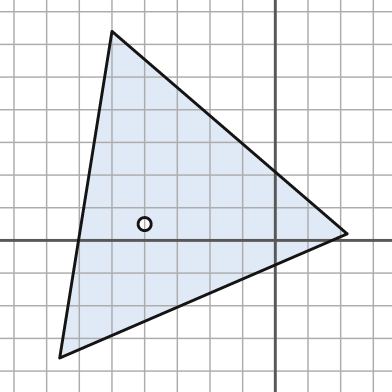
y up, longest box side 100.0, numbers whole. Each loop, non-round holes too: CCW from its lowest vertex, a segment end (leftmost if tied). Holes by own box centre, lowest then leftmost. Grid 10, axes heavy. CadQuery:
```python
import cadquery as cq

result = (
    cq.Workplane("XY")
    .moveTo(-66.0, -36.0)
    .lineTo(22.0, 2.0)
    .lineTo(-50.0, 64.0)
    .close()
    .moveTo(-40.0, 5.0)
    .circle(2.0)
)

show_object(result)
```